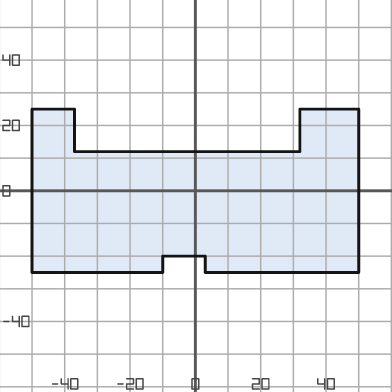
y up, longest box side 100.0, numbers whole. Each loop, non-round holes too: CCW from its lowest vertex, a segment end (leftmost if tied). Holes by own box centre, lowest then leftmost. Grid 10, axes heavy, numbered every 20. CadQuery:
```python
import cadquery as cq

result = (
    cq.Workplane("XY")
    .moveTo(-50.0, -25.0)
    .lineTo(-10.0, -25.0)
    .lineTo(-10.0, -20.0)
    .lineTo(3.0, -20.0)
    .lineTo(3.0, -25.0)
    .lineTo(50.0, -25.0)
    .lineTo(50.0, 25.0)
    .lineTo(32.0, 25.0)
    .lineTo(32.0, 12.0)
    .lineTo(-37.0, 12.0)
    .lineTo(-37.0, 25.0)
    .lineTo(-50.0, 25.0)
    .close()
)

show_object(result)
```